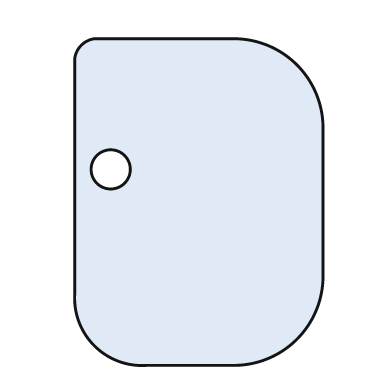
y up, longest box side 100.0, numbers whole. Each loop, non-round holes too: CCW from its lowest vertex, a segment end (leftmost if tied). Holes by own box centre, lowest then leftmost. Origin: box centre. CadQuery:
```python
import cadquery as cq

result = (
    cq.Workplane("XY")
    .moveTo(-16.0, -50.0)
    .lineTo(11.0, -50.0)
    .threePointArc((30.0, -42.0), (38.0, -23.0))
    .lineTo(38.0, 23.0)
    .threePointArc((30.0, 42.0), (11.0, 50.0))
    .lineTo(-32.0, 50.0)
    .threePointArc((-36.0, 48.0), (-38.0, 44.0))
    .lineTo(-38.0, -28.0)
    .threePointArc((-32.0, -44.0), (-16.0, -50.0))
    .close()
    .moveTo(-27.0, 10.0)
    .circle(6.0)
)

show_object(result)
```